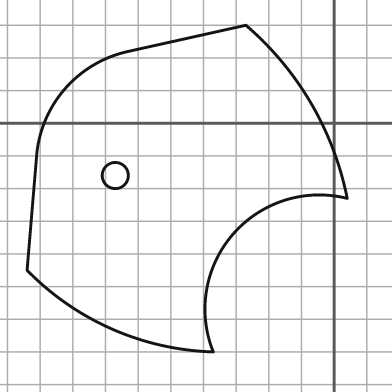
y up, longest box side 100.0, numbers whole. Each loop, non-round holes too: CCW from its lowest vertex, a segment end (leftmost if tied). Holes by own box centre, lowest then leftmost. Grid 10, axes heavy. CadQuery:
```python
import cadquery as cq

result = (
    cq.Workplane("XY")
    .moveTo(-37.0, -70.0)
    .threePointArc((-31.0, -34.0), (4.0, -23.0))
    .threePointArc((-7.0, 6.0), (-27.0, 30.0))
    .lineTo(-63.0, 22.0)
    .threePointArc((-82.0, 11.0), (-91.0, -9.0))
    .lineTo(-94.0, -45.0)
    .threePointArc((-68.0, -63.0), (-37.0, -70.0))
    .close()
    .moveTo(-67.0, -16.0)
    .circle(4.0)
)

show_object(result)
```